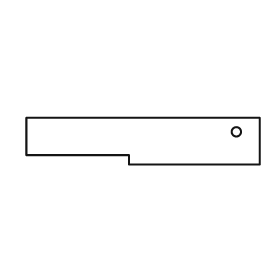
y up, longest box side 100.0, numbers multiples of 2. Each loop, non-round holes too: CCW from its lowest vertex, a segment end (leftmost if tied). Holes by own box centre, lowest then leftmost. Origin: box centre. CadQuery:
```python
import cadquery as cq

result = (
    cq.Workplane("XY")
    .moveTo(-6.0, -10.0)
    .lineTo(50.0, -10.0)
    .lineTo(50.0, 10.0)
    .lineTo(-50.0, 10.0)
    .lineTo(-50.0, -6.0)
    .lineTo(-6.0, -6.0)
    .close()
    .moveTo(40.0, 4.0)
    .circle(2.0)
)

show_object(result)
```